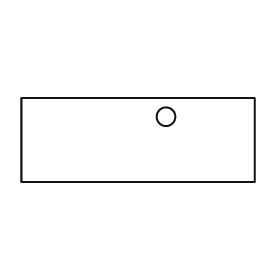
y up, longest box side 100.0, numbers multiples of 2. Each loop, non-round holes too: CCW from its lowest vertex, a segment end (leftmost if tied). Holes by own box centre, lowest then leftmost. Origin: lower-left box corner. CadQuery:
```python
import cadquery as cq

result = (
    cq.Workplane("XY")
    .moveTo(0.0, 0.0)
    .lineTo(100.0, 0.0)
    .lineTo(100.0, 36.0)
    .lineTo(0.0, 36.0)
    .close()
    .moveTo(62.0, 28.0)
    .circle(4.0)
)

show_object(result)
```